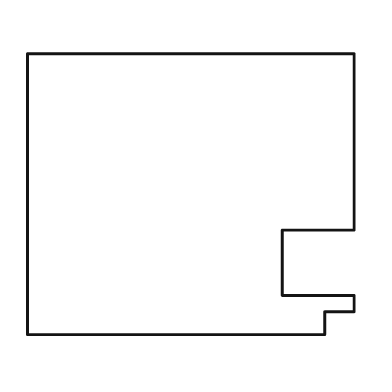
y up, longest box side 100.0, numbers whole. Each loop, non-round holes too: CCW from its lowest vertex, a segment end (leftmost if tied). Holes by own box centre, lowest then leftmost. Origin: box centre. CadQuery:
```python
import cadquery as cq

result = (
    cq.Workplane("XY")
    .moveTo(-50.0, -43.0)
    .lineTo(41.0, -43.0)
    .lineTo(41.0, -36.0)
    .lineTo(50.0, -36.0)
    .lineTo(50.0, -31.0)
    .lineTo(28.0, -31.0)
    .lineTo(28.0, -11.0)
    .lineTo(50.0, -11.0)
    .lineTo(50.0, 43.0)
    .lineTo(-50.0, 43.0)
    .close()
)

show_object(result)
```